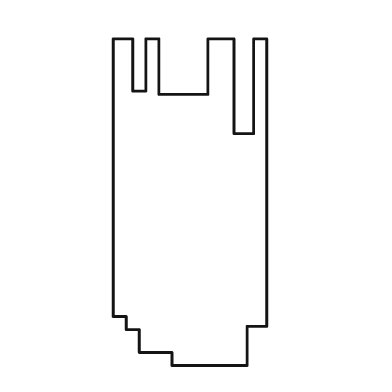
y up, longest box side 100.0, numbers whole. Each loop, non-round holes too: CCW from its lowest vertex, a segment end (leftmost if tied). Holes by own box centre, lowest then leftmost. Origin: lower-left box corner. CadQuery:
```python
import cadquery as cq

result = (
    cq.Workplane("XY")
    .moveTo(18.0, 0.0)
    .lineTo(41.0, 0.0)
    .lineTo(41.0, 12.0)
    .lineTo(47.0, 12.0)
    .lineTo(47.0, 100.0)
    .lineTo(43.0, 100.0)
    .lineTo(43.0, 71.0)
    .lineTo(37.0, 71.0)
    .lineTo(37.0, 100.0)
    .lineTo(29.0, 100.0)
    .lineTo(29.0, 83.0)
    .lineTo(14.0, 83.0)
    .lineTo(14.0, 100.0)
    .lineTo(10.0, 100.0)
    .lineTo(10.0, 84.0)
    .lineTo(6.0, 84.0)
    .lineTo(6.0, 100.0)
    .lineTo(0.0, 100.0)
    .lineTo(0.0, 15.0)
    .lineTo(4.0, 15.0)
    .lineTo(4.0, 11.0)
    .lineTo(8.0, 11.0)
    .lineTo(8.0, 4.0)
    .lineTo(18.0, 4.0)
    .close()
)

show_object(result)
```